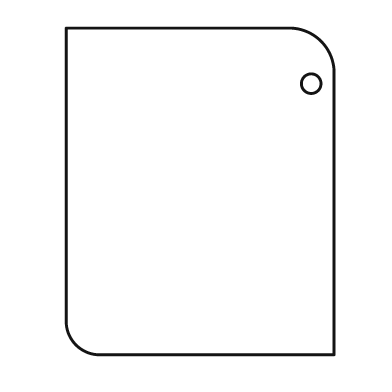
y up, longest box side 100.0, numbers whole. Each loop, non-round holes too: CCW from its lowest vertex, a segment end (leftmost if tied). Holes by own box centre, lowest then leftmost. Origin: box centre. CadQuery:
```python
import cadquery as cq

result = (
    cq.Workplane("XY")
    .moveTo(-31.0, -50.0)
    .lineTo(41.0, -50.0)
    .lineTo(41.0, 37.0)
    .threePointArc((37.0, 46.0), (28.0, 50.0))
    .lineTo(-41.0, 50.0)
    .lineTo(-41.0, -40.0)
    .threePointArc((-38.0, -47.0), (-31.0, -50.0))
    .close()
    .moveTo(34.0, 33.0)
    .circle(3.0)
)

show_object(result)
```